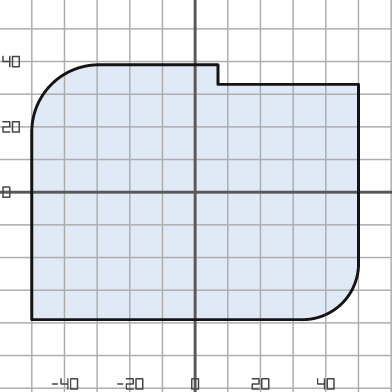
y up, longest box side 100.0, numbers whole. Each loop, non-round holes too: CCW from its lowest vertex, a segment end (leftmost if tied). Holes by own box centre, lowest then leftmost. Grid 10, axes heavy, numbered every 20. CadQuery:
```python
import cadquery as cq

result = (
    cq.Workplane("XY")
    .moveTo(-50.0, -39.0)
    .lineTo(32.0, -39.0)
    .threePointArc((45.0, -34.0), (50.0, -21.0))
    .lineTo(50.0, 33.0)
    .lineTo(7.0, 33.0)
    .lineTo(7.0, 39.0)
    .lineTo(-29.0, 39.0)
    .threePointArc((-44.0, 33.0), (-50.0, 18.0))
    .close()
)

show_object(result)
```